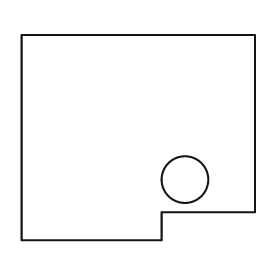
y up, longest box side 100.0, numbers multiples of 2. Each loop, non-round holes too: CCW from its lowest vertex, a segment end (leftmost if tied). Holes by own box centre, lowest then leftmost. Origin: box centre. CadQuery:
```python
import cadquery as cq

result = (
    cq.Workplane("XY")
    .moveTo(-50.0, -44.0)
    .lineTo(10.0, -44.0)
    .lineTo(10.0, -32.0)
    .lineTo(50.0, -32.0)
    .lineTo(50.0, 44.0)
    .lineTo(-50.0, 44.0)
    .close()
    .moveTo(20.0, -18.0)
    .circle(10.0)
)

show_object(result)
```